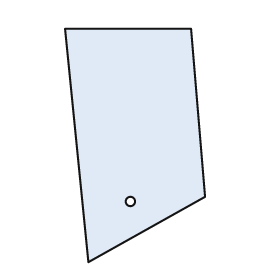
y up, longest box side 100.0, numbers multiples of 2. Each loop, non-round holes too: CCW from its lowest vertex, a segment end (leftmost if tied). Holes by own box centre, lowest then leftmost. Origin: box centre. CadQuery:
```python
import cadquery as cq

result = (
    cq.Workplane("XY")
    .moveTo(-20.0, -50.0)
    .lineTo(30.0, -22.0)
    .lineTo(24.0, 50.0)
    .lineTo(-30.0, 50.0)
    .close()
    .moveTo(-2.0, -24.0)
    .circle(2.0)
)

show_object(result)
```